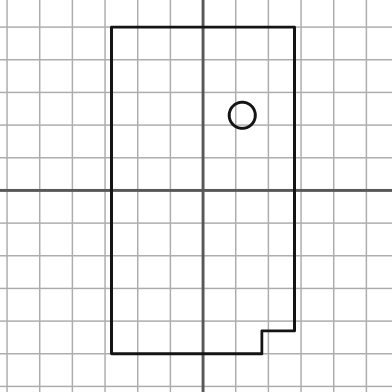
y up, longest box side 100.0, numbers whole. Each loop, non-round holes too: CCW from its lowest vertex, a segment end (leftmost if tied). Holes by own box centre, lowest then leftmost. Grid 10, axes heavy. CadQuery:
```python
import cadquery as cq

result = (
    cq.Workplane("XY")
    .moveTo(-28.0, -50.0)
    .lineTo(18.0, -50.0)
    .lineTo(18.0, -43.0)
    .lineTo(28.0, -43.0)
    .lineTo(28.0, 50.0)
    .lineTo(-28.0, 50.0)
    .close()
    .moveTo(12.0, 23.0)
    .circle(4.0)
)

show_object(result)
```